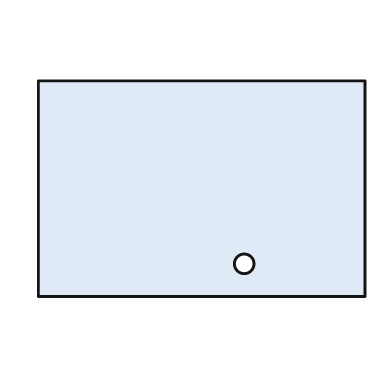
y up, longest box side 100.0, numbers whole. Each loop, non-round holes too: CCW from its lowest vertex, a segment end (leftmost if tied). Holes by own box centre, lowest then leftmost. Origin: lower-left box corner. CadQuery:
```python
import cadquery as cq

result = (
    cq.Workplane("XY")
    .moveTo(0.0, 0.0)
    .lineTo(100.0, 0.0)
    .lineTo(100.0, 66.0)
    .lineTo(0.0, 66.0)
    .close()
    .moveTo(63.0, 10.0)
    .circle(3.0)
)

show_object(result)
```